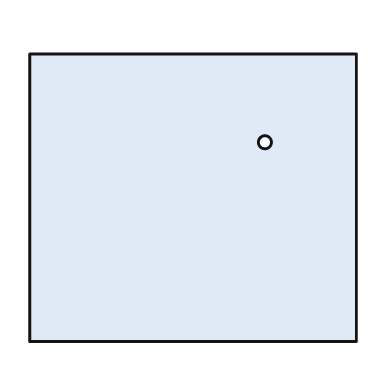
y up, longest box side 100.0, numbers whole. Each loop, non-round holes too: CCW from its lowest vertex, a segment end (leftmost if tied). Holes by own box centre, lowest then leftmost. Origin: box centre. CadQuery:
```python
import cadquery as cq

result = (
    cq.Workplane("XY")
    .moveTo(-50.0, -44.0)
    .lineTo(50.0, -44.0)
    .lineTo(50.0, 44.0)
    .lineTo(-50.0, 44.0)
    .close()
    .moveTo(22.0, 17.0)
    .circle(2.0)
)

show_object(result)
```